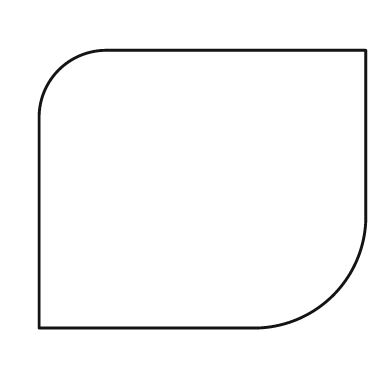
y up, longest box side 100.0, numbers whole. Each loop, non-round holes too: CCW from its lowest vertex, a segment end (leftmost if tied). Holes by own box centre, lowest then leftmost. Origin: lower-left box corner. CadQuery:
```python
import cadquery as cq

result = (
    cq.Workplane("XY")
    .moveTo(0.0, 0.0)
    .lineTo(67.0, 0.0)
    .threePointArc((90.0, 10.0), (100.0, 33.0))
    .lineTo(100.0, 85.0)
    .lineTo(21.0, 85.0)
    .threePointArc((6.0, 79.0), (0.0, 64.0))
    .close()
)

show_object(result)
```